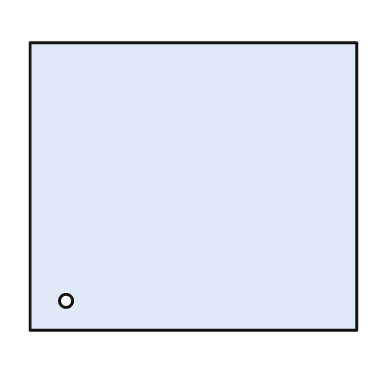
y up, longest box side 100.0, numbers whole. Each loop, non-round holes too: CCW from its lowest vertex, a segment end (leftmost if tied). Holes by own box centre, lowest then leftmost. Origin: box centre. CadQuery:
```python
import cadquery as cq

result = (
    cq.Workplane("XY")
    .moveTo(-50.0, -44.0)
    .lineTo(50.0, -44.0)
    .lineTo(50.0, 44.0)
    .lineTo(-50.0, 44.0)
    .close()
    .moveTo(-39.0, -35.0)
    .circle(2.0)
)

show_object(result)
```